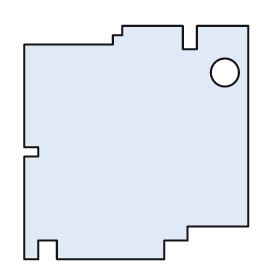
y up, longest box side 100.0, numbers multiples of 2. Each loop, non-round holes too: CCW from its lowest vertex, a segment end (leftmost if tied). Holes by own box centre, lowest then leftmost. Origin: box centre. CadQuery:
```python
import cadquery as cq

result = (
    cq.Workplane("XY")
    .moveTo(-48.0, -50.0)
    .lineTo(-42.0, -50.0)
    .lineTo(-42.0, -42.0)
    .lineTo(-34.0, -42.0)
    .lineTo(-34.0, -50.0)
    .lineTo(12.0, -50.0)
    .lineTo(12.0, -42.0)
    .lineTo(22.0, -42.0)
    .lineTo(22.0, -36.0)
    .lineTo(48.0, -36.0)
    .lineTo(48.0, 50.0)
    .lineTo(26.0, 50.0)
    .lineTo(26.0, 40.0)
    .lineTo(20.0, 40.0)
    .lineTo(20.0, 50.0)
    .lineTo(-6.0, 50.0)
    .lineTo(-6.0, 46.0)
    .lineTo(-10.0, 46.0)
    .lineTo(-10.0, 42.0)
    .lineTo(-48.0, 42.0)
    .lineTo(-48.0, -2.0)
    .lineTo(-42.0, -2.0)
    .lineTo(-42.0, -6.0)
    .lineTo(-48.0, -6.0)
    .close()
    .moveTo(38.0, 30.0)
    .circle(6.0)
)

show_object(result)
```